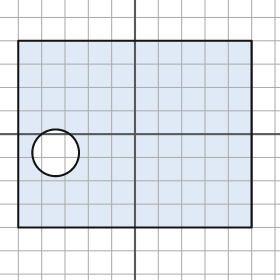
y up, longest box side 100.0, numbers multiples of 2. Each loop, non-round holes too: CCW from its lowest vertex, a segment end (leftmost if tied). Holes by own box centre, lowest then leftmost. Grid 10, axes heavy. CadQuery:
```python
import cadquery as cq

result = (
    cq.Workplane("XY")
    .moveTo(-50.0, -40.0)
    .lineTo(50.0, -40.0)
    .lineTo(50.0, 40.0)
    .lineTo(-50.0, 40.0)
    .close()
    .moveTo(-34.0, -8.0)
    .circle(10.0)
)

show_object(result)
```